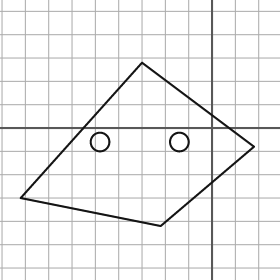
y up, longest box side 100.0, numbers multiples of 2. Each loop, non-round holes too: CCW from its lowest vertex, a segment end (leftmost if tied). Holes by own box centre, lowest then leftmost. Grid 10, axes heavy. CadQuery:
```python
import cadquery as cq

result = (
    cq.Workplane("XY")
    .moveTo(-22.0, -42.0)
    .lineTo(18.0, -8.0)
    .lineTo(-30.0, 28.0)
    .lineTo(-82.0, -30.0)
    .close()
    .moveTo(-48.0, -6.0)
    .circle(4.0)
    .moveTo(-14.0, -6.0)
    .circle(4.0)
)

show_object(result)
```